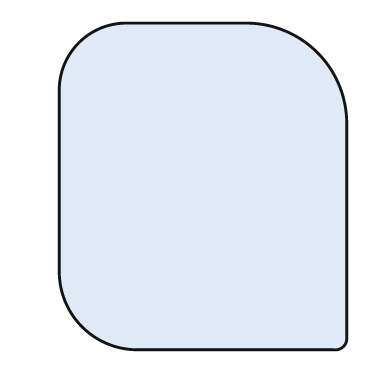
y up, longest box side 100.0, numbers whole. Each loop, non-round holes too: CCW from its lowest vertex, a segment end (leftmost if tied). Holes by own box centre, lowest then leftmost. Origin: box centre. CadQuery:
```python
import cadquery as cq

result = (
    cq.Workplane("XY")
    .moveTo(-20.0, -50.0)
    .lineTo(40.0, -50.0)
    .threePointArc((43.0, -49.0), (44.0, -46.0))
    .lineTo(44.0, 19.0)
    .threePointArc((35.0, 41.0), (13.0, 50.0))
    .lineTo(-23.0, 50.0)
    .threePointArc((-38.0, 44.0), (-44.0, 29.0))
    .lineTo(-44.0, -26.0)
    .threePointArc((-37.0, -43.0), (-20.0, -50.0))
    .close()
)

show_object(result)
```